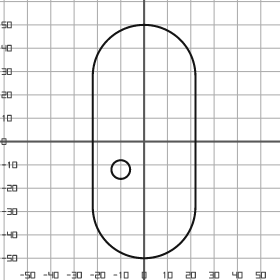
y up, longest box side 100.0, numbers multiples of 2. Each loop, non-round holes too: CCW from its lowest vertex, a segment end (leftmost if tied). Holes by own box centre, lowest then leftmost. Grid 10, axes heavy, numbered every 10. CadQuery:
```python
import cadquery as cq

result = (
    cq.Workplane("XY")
    .moveTo(-22.0, -28.0)
    .threePointArc((0.0, -50.0), (22.0, -28.0))
    .lineTo(22.0, 28.0)
    .threePointArc((0.0, 50.0), (-22.0, 28.0))
    .close()
    .moveTo(-10.0, -12.0)
    .circle(4.0)
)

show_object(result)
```